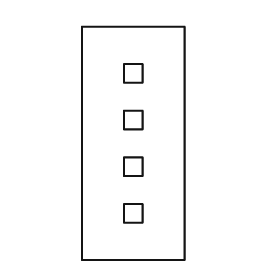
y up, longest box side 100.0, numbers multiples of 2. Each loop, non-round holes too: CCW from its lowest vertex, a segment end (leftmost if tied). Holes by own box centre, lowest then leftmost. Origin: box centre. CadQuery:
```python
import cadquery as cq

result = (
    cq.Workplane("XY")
    .moveTo(-22.0, -50.0)
    .lineTo(22.0, -50.0)
    .lineTo(22.0, 50.0)
    .lineTo(-22.0, 50.0)
    .close()
    .moveTo(-4.0, -34.0)
    .lineTo(4.0, -34.0)
    .lineTo(4.0, -26.0)
    .lineTo(-4.0, -26.0)
    .close()
    .moveTo(-4.0, -14.0)
    .lineTo(4.0, -14.0)
    .lineTo(4.0, -6.0)
    .lineTo(-4.0, -6.0)
    .close()
    .moveTo(-4.0, 6.0)
    .lineTo(4.0, 6.0)
    .lineTo(4.0, 14.0)
    .lineTo(-4.0, 14.0)
    .close()
    .moveTo(-4.0, 26.0)
    .lineTo(4.0, 26.0)
    .lineTo(4.0, 34.0)
    .lineTo(-4.0, 34.0)
    .close()
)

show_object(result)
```